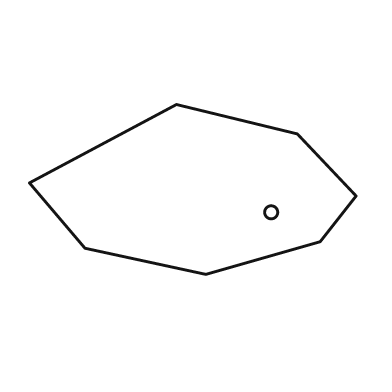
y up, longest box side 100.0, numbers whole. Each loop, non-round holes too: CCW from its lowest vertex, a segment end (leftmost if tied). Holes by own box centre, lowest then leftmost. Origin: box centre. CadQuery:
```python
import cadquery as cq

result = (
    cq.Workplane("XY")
    .moveTo(4.0, -26.0)
    .lineTo(39.0, -16.0)
    .lineTo(50.0, -2.0)
    .lineTo(32.0, 17.0)
    .lineTo(-5.0, 26.0)
    .lineTo(-50.0, 2.0)
    .lineTo(-33.0, -18.0)
    .close()
    .moveTo(24.0, -7.0)
    .circle(2.0)
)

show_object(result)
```